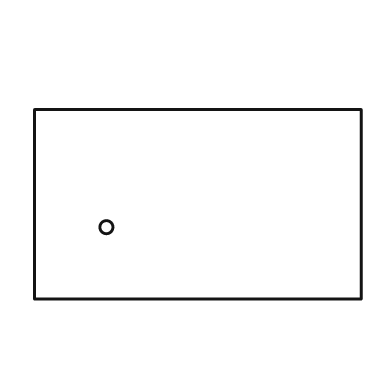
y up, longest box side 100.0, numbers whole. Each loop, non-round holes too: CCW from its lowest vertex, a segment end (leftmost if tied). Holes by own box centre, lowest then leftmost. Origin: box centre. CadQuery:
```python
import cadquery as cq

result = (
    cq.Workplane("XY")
    .moveTo(-50.0, -29.0)
    .lineTo(50.0, -29.0)
    .lineTo(50.0, 29.0)
    .lineTo(-50.0, 29.0)
    .close()
    .moveTo(-28.0, -7.0)
    .circle(2.0)
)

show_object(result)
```